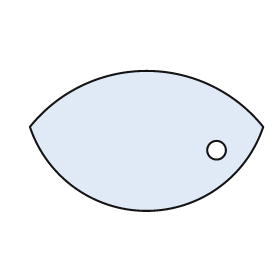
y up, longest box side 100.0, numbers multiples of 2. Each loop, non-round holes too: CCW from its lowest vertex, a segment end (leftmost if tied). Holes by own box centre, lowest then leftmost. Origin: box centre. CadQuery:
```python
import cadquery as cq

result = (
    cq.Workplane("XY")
    .moveTo(-50.0, 6.0)
    .threePointArc((0.0, -30.0), (50.0, 6.0))
    .threePointArc((0.0, 30.0), (-50.0, 6.0))
    .close()
    .moveTo(30.0, -4.0)
    .circle(4.0)
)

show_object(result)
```